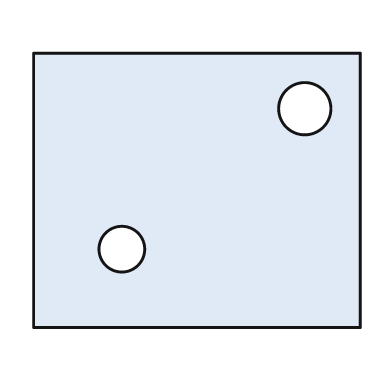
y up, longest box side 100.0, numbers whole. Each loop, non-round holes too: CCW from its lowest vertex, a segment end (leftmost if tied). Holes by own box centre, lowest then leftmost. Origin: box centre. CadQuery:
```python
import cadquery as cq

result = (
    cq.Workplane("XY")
    .moveTo(-50.0, -42.0)
    .lineTo(50.0, -42.0)
    .lineTo(50.0, 42.0)
    .lineTo(-50.0, 42.0)
    .close()
    .moveTo(-23.0, -18.0)
    .circle(7.0)
    .moveTo(33.0, 25.0)
    .circle(8.0)
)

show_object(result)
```